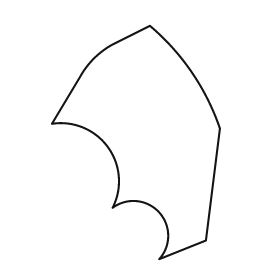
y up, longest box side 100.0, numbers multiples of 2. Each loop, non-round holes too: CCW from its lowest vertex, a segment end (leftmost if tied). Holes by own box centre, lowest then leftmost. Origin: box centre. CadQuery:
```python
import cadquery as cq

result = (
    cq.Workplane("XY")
    .moveTo(10.0, -50.0)
    .lineTo(30.0, -42.0)
    .lineTo(36.0, 6.0)
    .threePointArc((24.0, 30.0), (6.0, 50.0))
    .lineTo(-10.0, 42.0)
    .threePointArc((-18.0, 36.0), (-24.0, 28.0))
    .lineTo(-36.0, 8.0)
    .threePointArc((-12.0, -2.0), (-10.0, -28.0))
    .threePointArc((10.0, -30.0), (10.0, -50.0))
    .close()
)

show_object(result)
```